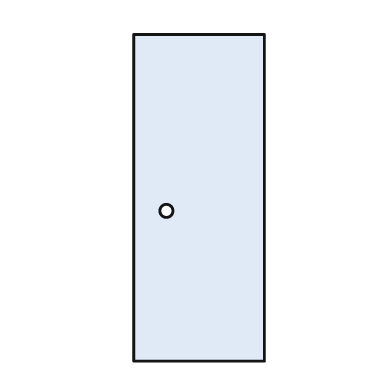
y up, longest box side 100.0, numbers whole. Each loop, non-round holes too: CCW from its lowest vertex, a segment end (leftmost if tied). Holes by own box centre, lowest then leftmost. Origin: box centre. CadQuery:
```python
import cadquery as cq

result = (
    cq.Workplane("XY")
    .moveTo(-20.0, -50.0)
    .lineTo(20.0, -50.0)
    .lineTo(20.0, 50.0)
    .lineTo(-20.0, 50.0)
    .close()
    .moveTo(-10.0, -4.0)
    .circle(2.0)
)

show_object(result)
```